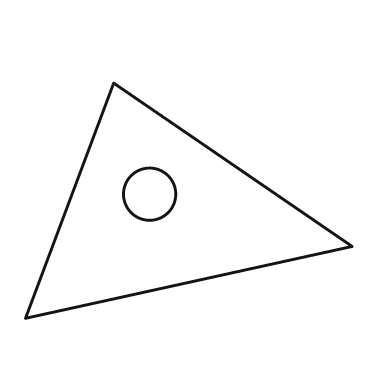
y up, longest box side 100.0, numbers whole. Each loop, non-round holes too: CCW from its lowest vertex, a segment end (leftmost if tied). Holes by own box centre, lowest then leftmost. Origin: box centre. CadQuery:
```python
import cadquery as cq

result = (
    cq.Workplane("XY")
    .moveTo(-50.0, -36.0)
    .lineTo(50.0, -14.0)
    .lineTo(-23.0, 36.0)
    .close()
    .moveTo(-12.0, 2.0)
    .circle(8.0)
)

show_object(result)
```